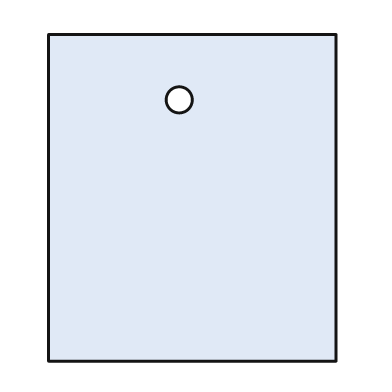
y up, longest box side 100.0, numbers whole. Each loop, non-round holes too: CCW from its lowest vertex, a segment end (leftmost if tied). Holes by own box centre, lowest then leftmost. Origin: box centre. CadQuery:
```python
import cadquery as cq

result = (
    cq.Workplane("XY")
    .moveTo(-44.0, -50.0)
    .lineTo(44.0, -50.0)
    .lineTo(44.0, 50.0)
    .lineTo(-44.0, 50.0)
    .close()
    .moveTo(-4.0, 30.0)
    .circle(4.0)
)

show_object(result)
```